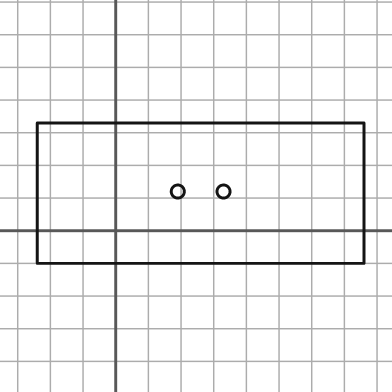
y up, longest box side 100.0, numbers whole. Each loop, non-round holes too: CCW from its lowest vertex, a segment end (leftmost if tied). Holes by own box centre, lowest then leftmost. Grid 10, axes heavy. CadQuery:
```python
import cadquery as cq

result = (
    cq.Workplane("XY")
    .moveTo(-24.0, -10.0)
    .lineTo(76.0, -10.0)
    .lineTo(76.0, 33.0)
    .lineTo(-24.0, 33.0)
    .close()
    .moveTo(19.0, 12.0)
    .circle(2.0)
    .moveTo(33.0, 12.0)
    .circle(2.0)
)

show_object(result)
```